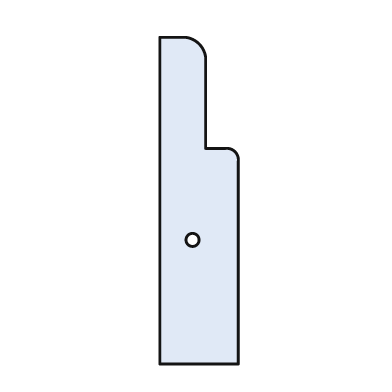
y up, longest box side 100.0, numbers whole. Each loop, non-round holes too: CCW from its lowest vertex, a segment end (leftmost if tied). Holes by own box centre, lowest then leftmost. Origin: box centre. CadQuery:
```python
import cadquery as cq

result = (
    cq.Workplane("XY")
    .moveTo(-12.0, -50.0)
    .lineTo(12.0, -50.0)
    .lineTo(12.0, 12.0)
    .threePointArc((11.0, 15.0), (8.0, 16.0))
    .lineTo(2.0, 16.0)
    .lineTo(2.0, 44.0)
    .threePointArc((0.0, 48.0), (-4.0, 50.0))
    .lineTo(-12.0, 50.0)
    .close()
    .moveTo(-2.0, -12.0)
    .circle(2.0)
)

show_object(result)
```